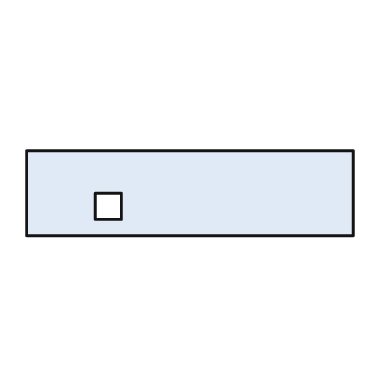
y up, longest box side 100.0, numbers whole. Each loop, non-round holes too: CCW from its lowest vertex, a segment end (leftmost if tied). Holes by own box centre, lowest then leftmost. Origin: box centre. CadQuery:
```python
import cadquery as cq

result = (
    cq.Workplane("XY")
    .moveTo(-50.0, -13.0)
    .lineTo(50.0, -13.0)
    .lineTo(50.0, 13.0)
    .lineTo(-50.0, 13.0)
    .close()
    .moveTo(-29.0, -8.0)
    .lineTo(-21.0, -8.0)
    .lineTo(-21.0, 0.0)
    .lineTo(-29.0, 0.0)
    .close()
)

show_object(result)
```